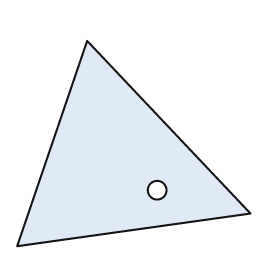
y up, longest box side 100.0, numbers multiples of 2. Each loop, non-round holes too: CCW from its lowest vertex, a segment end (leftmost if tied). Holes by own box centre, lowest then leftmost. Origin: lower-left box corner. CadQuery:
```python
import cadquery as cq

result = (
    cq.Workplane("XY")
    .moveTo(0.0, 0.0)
    .lineTo(100.0, 14.0)
    .lineTo(30.0, 88.0)
    .close()
    .moveTo(60.0, 24.0)
    .circle(4.0)
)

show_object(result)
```